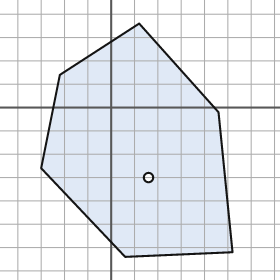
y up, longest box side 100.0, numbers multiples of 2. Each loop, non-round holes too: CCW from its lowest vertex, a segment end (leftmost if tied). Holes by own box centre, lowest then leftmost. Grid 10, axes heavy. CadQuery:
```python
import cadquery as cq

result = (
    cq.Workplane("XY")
    .moveTo(6.0, -64.0)
    .lineTo(52.0, -62.0)
    .lineTo(46.0, -2.0)
    .lineTo(12.0, 36.0)
    .lineTo(-22.0, 14.0)
    .lineTo(-30.0, -26.0)
    .close()
    .moveTo(16.0, -30.0)
    .circle(2.0)
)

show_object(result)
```